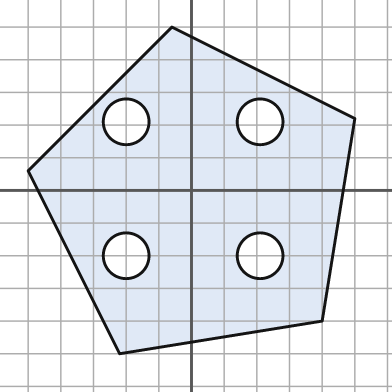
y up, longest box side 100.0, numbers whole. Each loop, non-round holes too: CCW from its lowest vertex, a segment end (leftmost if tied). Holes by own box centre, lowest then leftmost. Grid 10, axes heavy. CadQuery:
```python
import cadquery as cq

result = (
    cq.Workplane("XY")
    .moveTo(-22.0, -50.0)
    .lineTo(40.0, -40.0)
    .lineTo(50.0, 22.0)
    .lineTo(-6.0, 50.0)
    .lineTo(-50.0, 6.0)
    .close()
    .moveTo(-20.0, -20.0)
    .circle(7.0)
    .moveTo(21.0, -20.0)
    .circle(7.0)
    .moveTo(-20.0, 21.0)
    .circle(7.0)
    .moveTo(21.0, 21.0)
    .circle(7.0)
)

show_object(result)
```